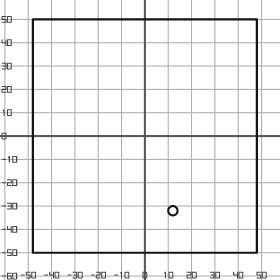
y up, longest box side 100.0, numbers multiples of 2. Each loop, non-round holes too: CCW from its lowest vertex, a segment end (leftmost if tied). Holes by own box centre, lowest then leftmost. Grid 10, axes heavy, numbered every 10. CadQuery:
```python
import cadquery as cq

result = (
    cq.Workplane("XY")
    .moveTo(-48.0, -50.0)
    .lineTo(48.0, -50.0)
    .lineTo(48.0, 50.0)
    .lineTo(-48.0, 50.0)
    .close()
    .moveTo(12.0, -32.0)
    .circle(2.0)
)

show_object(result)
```